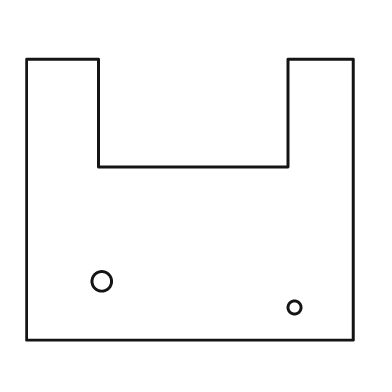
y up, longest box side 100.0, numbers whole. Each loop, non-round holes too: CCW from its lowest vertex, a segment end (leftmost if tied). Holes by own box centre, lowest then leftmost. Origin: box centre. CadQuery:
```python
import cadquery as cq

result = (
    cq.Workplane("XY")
    .moveTo(-50.0, -43.0)
    .lineTo(50.0, -43.0)
    .lineTo(50.0, 43.0)
    .lineTo(30.0, 43.0)
    .lineTo(30.0, 10.0)
    .lineTo(-28.0, 10.0)
    .lineTo(-28.0, 43.0)
    .lineTo(-50.0, 43.0)
    .close()
    .moveTo(32.0, -33.0)
    .circle(2.0)
    .moveTo(-27.0, -25.0)
    .circle(3.0)
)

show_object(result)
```